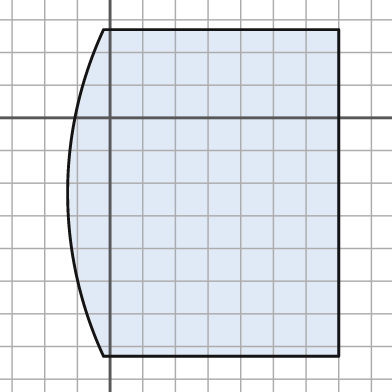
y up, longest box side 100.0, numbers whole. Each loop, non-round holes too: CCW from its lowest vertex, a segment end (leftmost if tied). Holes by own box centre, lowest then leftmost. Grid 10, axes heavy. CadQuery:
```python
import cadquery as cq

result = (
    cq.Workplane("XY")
    .moveTo(-2.0, -73.0)
    .lineTo(70.0, -73.0)
    .lineTo(70.0, 27.0)
    .lineTo(-2.0, 27.0)
    .threePointArc((-13.0, -23.0), (-2.0, -73.0))
    .close()
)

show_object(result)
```